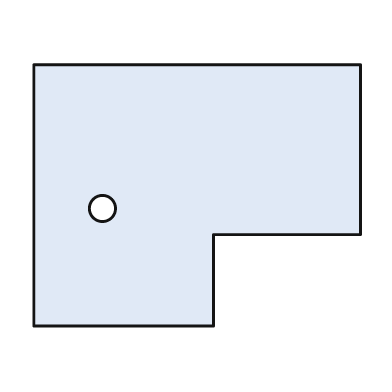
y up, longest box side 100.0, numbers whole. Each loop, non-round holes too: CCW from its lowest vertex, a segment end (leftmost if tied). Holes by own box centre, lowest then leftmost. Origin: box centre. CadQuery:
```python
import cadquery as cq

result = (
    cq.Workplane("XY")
    .moveTo(-50.0, -40.0)
    .lineTo(5.0, -40.0)
    .lineTo(5.0, -12.0)
    .lineTo(50.0, -12.0)
    .lineTo(50.0, 40.0)
    .lineTo(-50.0, 40.0)
    .close()
    .moveTo(-29.0, -4.0)
    .circle(4.0)
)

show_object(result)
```